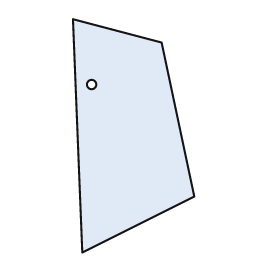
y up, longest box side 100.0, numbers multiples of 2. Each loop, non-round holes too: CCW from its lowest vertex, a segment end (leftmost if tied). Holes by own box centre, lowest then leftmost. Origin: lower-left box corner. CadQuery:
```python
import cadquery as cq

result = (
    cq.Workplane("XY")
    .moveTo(4.0, 0.0)
    .lineTo(52.0, 24.0)
    .lineTo(38.0, 90.0)
    .lineTo(0.0, 100.0)
    .close()
    .moveTo(8.0, 72.0)
    .circle(2.0)
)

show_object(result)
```